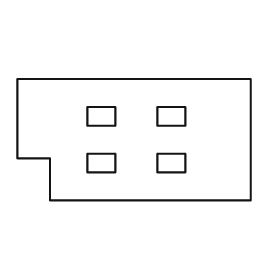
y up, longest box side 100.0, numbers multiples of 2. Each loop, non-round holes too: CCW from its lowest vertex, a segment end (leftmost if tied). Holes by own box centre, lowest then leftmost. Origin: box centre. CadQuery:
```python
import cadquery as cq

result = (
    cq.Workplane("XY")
    .moveTo(-36.0, -26.0)
    .lineTo(50.0, -26.0)
    .lineTo(50.0, 26.0)
    .lineTo(-50.0, 26.0)
    .lineTo(-50.0, -8.0)
    .lineTo(-36.0, -8.0)
    .close()
    .moveTo(-20.0, -14.0)
    .lineTo(-8.0, -14.0)
    .lineTo(-8.0, -6.0)
    .lineTo(-20.0, -6.0)
    .close()
    .moveTo(10.0, -14.0)
    .lineTo(22.0, -14.0)
    .lineTo(22.0, -6.0)
    .lineTo(10.0, -6.0)
    .close()
    .moveTo(-20.0, 6.0)
    .lineTo(-8.0, 6.0)
    .lineTo(-8.0, 14.0)
    .lineTo(-20.0, 14.0)
    .close()
    .moveTo(10.0, 6.0)
    .lineTo(22.0, 6.0)
    .lineTo(22.0, 14.0)
    .lineTo(10.0, 14.0)
    .close()
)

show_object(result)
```